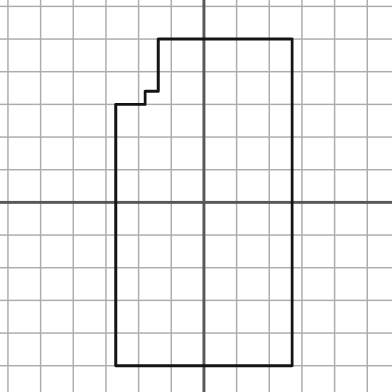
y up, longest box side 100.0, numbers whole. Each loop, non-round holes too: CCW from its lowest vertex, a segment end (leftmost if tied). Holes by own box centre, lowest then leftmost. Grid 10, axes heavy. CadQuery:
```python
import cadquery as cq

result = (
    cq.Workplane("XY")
    .moveTo(-27.0, -50.0)
    .lineTo(27.0, -50.0)
    .lineTo(27.0, 50.0)
    .lineTo(-14.0, 50.0)
    .lineTo(-14.0, 34.0)
    .lineTo(-18.0, 34.0)
    .lineTo(-18.0, 30.0)
    .lineTo(-27.0, 30.0)
    .close()
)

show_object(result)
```